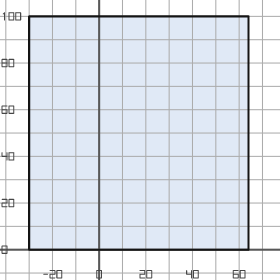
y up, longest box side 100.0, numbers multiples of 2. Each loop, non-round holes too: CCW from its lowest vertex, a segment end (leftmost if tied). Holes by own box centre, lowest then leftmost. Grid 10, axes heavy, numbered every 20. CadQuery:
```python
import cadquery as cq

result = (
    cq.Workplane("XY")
    .moveTo(-30.0, 0.0)
    .lineTo(64.0, 0.0)
    .lineTo(64.0, 100.0)
    .lineTo(-30.0, 100.0)
    .close()
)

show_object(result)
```